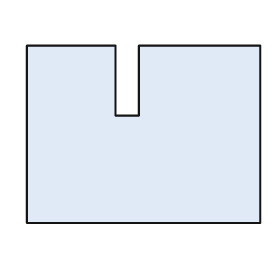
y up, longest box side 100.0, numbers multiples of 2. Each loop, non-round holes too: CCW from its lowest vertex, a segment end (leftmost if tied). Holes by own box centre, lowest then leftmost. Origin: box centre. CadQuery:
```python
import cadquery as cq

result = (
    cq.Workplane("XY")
    .moveTo(-50.0, -38.0)
    .lineTo(50.0, -38.0)
    .lineTo(50.0, 38.0)
    .lineTo(-2.0, 38.0)
    .lineTo(-2.0, 8.0)
    .lineTo(-12.0, 8.0)
    .lineTo(-12.0, 38.0)
    .lineTo(-50.0, 38.0)
    .close()
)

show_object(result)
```